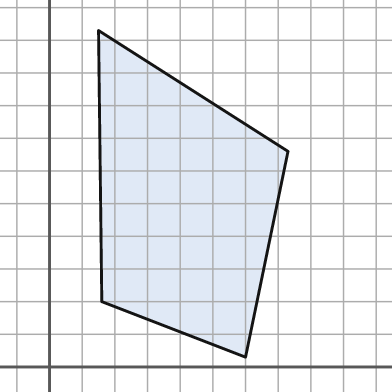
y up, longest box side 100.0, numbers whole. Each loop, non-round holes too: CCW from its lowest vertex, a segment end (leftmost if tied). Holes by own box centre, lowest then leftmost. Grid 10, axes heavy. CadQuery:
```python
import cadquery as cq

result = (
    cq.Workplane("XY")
    .moveTo(60.0, 3.0)
    .lineTo(73.0, 66.0)
    .lineTo(15.0, 103.0)
    .lineTo(16.0, 20.0)
    .close()
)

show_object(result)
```